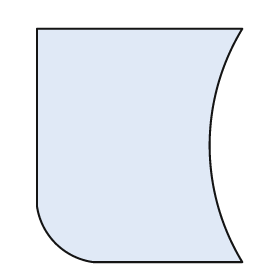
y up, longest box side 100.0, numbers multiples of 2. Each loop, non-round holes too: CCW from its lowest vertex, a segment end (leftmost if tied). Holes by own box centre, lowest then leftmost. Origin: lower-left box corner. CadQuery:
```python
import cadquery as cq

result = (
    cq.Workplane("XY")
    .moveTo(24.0, 0.0)
    .lineTo(88.0, 0.0)
    .threePointArc((74.0, 50.0), (88.0, 100.0))
    .lineTo(0.0, 100.0)
    .lineTo(0.0, 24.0)
    .threePointArc((8.0, 8.0), (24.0, 0.0))
    .close()
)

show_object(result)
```